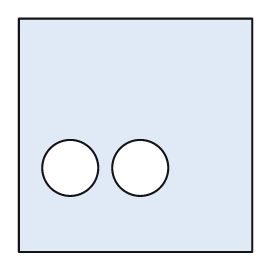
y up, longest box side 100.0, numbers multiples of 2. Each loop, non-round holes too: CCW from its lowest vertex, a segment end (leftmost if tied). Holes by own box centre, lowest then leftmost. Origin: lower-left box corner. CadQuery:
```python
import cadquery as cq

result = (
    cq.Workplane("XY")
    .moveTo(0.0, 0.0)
    .lineTo(100.0, 0.0)
    .lineTo(100.0, 100.0)
    .lineTo(0.0, 100.0)
    .close()
    .moveTo(22.0, 36.0)
    .circle(12.0)
    .moveTo(52.0, 36.0)
    .circle(12.0)
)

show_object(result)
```